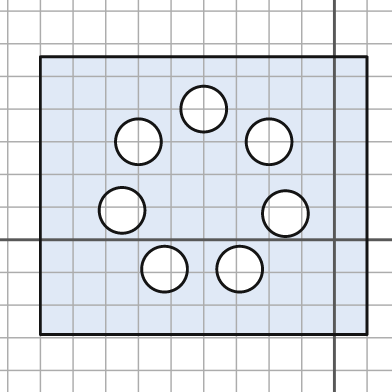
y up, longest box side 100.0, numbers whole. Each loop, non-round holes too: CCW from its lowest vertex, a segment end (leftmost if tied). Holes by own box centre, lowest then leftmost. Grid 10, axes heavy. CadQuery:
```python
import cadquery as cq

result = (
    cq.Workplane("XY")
    .moveTo(-90.0, -29.0)
    .lineTo(10.0, -29.0)
    .lineTo(10.0, 56.0)
    .lineTo(-90.0, 56.0)
    .close()
    .moveTo(-52.0, -9.0)
    .circle(7.0)
    .moveTo(-29.0, -9.0)
    .circle(7.0)
    .moveTo(-15.0, 8.0)
    .circle(7.0)
    .moveTo(-65.0, 9.0)
    .circle(7.0)
    .moveTo(-60.0, 30.0)
    .circle(7.0)
    .moveTo(-20.0, 30.0)
    .circle(7.0)
    .moveTo(-40.0, 40.0)
    .circle(7.0)
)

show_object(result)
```